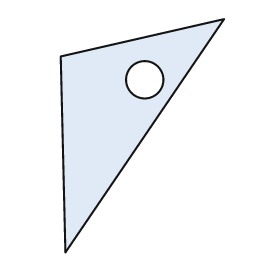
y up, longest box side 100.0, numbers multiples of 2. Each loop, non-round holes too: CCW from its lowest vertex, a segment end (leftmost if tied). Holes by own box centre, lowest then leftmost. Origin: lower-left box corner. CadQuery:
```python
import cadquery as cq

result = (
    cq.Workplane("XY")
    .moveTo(2.0, 0.0)
    .lineTo(70.0, 100.0)
    .lineTo(0.0, 84.0)
    .close()
    .moveTo(36.0, 74.0)
    .circle(8.0)
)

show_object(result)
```